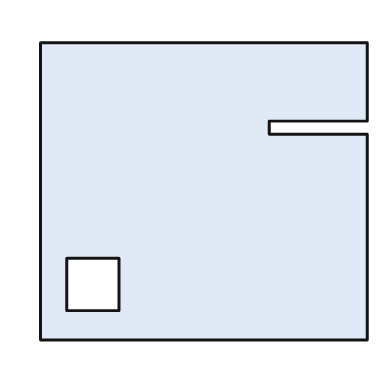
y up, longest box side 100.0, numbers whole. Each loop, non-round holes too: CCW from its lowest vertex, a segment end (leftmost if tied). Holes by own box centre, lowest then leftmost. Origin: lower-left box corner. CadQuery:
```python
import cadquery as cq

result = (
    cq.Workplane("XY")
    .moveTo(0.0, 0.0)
    .lineTo(100.0, 0.0)
    .lineTo(100.0, 63.0)
    .lineTo(70.0, 63.0)
    .lineTo(70.0, 67.0)
    .lineTo(100.0, 67.0)
    .lineTo(100.0, 91.0)
    .lineTo(0.0, 91.0)
    .close()
    .moveTo(8.0, 9.0)
    .lineTo(24.0, 9.0)
    .lineTo(24.0, 25.0)
    .lineTo(8.0, 25.0)
    .close()
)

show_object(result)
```